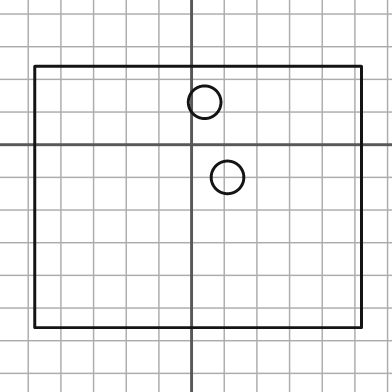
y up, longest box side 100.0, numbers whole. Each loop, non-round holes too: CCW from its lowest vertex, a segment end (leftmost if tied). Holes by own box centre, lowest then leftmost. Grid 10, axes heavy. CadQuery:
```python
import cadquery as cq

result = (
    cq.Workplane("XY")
    .moveTo(-48.0, -56.0)
    .lineTo(52.0, -56.0)
    .lineTo(52.0, 24.0)
    .lineTo(-48.0, 24.0)
    .close()
    .moveTo(11.0, -10.0)
    .circle(5.0)
    .moveTo(4.0, 13.0)
    .circle(5.0)
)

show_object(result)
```